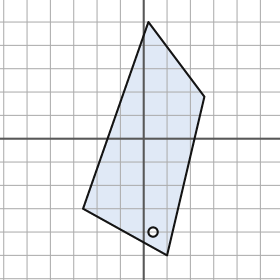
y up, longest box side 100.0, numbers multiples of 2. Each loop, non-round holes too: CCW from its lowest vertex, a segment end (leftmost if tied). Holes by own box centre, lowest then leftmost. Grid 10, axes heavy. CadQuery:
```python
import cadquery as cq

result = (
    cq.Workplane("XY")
    .moveTo(10.0, -50.0)
    .lineTo(26.0, 18.0)
    .lineTo(2.0, 50.0)
    .lineTo(-26.0, -30.0)
    .close()
    .moveTo(4.0, -40.0)
    .circle(2.0)
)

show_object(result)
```